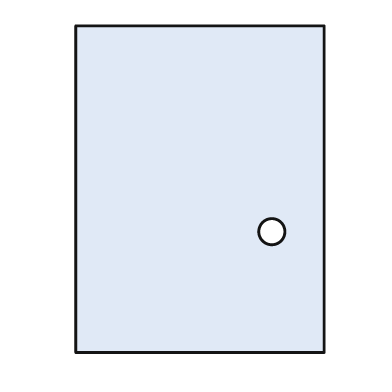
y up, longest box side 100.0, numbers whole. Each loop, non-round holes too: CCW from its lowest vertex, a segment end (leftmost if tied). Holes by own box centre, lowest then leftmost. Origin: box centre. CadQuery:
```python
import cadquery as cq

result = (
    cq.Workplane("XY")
    .moveTo(-38.0, -50.0)
    .lineTo(38.0, -50.0)
    .lineTo(38.0, 50.0)
    .lineTo(-38.0, 50.0)
    .close()
    .moveTo(22.0, -13.0)
    .circle(4.0)
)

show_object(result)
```